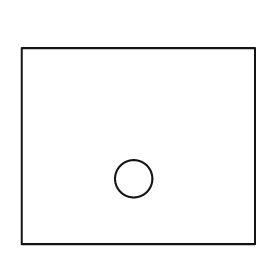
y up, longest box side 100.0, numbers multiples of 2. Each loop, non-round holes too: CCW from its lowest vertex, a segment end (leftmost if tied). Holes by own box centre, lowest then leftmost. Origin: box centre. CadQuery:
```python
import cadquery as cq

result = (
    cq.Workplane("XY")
    .moveTo(-50.0, -42.0)
    .lineTo(50.0, -42.0)
    .lineTo(50.0, 42.0)
    .lineTo(-50.0, 42.0)
    .close()
    .moveTo(-2.0, -14.0)
    .circle(8.0)
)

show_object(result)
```